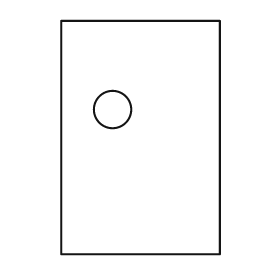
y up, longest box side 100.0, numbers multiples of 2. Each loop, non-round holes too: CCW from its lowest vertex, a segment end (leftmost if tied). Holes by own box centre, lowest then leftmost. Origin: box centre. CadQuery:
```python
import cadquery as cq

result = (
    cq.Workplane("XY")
    .moveTo(-34.0, -50.0)
    .lineTo(34.0, -50.0)
    .lineTo(34.0, 50.0)
    .lineTo(-34.0, 50.0)
    .close()
    .moveTo(-12.0, 12.0)
    .circle(8.0)
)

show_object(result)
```